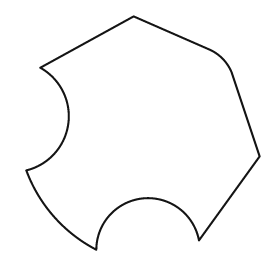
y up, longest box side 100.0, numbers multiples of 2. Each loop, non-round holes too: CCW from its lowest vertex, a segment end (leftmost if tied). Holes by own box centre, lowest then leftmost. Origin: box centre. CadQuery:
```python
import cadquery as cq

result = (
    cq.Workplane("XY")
    .moveTo(-20.0, -50.0)
    .threePointArc((0.0, -28.0), (24.0, -46.0))
    .lineTo(50.0, -10.0)
    .lineTo(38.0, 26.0)
    .threePointArc((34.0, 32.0), (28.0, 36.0))
    .lineTo(-4.0, 50.0)
    .lineTo(-44.0, 28.0)
    .threePointArc((-32.0, 4.0), (-50.0, -16.0))
    .threePointArc((-38.0, -36.0), (-20.0, -50.0))
    .close()
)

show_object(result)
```